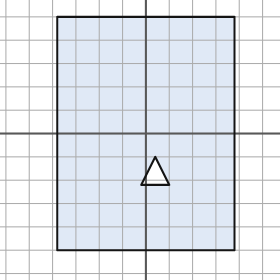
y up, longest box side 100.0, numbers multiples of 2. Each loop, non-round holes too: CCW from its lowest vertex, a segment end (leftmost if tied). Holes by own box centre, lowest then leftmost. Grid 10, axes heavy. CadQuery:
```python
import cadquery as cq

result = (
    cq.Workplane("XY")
    .moveTo(-38.0, -50.0)
    .lineTo(38.0, -50.0)
    .lineTo(38.0, 50.0)
    .lineTo(-38.0, 50.0)
    .close()
    .moveTo(-2.0, -22.0)
    .lineTo(10.0, -22.0)
    .lineTo(4.0, -10.0)
    .close()
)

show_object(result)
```